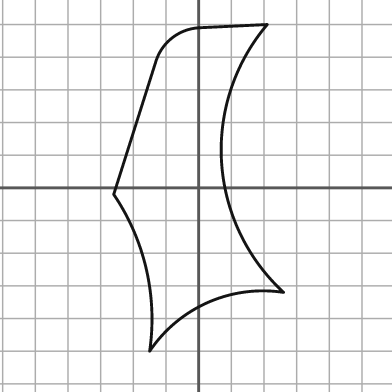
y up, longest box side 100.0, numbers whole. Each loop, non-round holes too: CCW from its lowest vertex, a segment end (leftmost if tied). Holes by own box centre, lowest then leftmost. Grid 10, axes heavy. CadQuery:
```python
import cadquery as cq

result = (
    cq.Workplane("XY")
    .moveTo(-15.0, -50.0)
    .threePointArc((3.0, -35.0), (26.0, -32.0))
    .threePointArc((7.0, 8.0), (21.0, 50.0))
    .lineTo(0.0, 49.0)
    .threePointArc((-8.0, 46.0), (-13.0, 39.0))
    .lineTo(-26.0, -2.0)
    .threePointArc((-16.0, -25.0), (-15.0, -50.0))
    .close()
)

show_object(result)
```